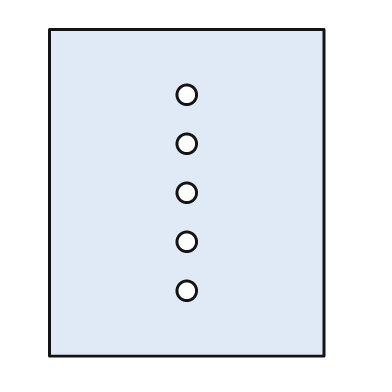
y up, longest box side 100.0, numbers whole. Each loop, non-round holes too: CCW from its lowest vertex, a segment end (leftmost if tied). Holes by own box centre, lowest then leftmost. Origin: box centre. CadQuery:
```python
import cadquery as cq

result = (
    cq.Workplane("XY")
    .moveTo(-42.0, -50.0)
    .lineTo(42.0, -50.0)
    .lineTo(42.0, 50.0)
    .lineTo(-42.0, 50.0)
    .close()
    .moveTo(0.0, -30.0)
    .circle(3.0)
    .moveTo(0.0, -15.0)
    .circle(3.0)
    .moveTo(0.0, 0.0)
    .circle(3.0)
    .moveTo(0.0, 15.0)
    .circle(3.0)
    .moveTo(0.0, 30.0)
    .circle(3.0)
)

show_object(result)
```